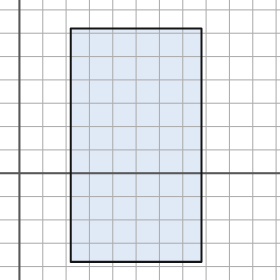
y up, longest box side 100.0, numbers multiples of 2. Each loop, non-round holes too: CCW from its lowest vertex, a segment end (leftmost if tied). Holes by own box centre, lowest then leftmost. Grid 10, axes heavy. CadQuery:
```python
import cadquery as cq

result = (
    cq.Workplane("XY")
    .moveTo(22.0, -38.0)
    .lineTo(78.0, -38.0)
    .lineTo(78.0, 62.0)
    .lineTo(22.0, 62.0)
    .close()
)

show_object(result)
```